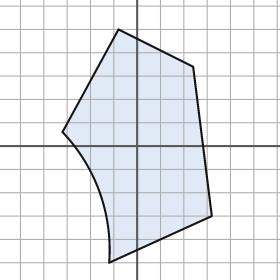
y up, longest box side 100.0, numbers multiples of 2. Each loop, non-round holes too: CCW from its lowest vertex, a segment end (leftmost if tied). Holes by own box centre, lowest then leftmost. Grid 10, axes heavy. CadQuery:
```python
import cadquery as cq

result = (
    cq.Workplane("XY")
    .moveTo(-12.0, -50.0)
    .lineTo(32.0, -30.0)
    .lineTo(24.0, 34.0)
    .lineTo(-8.0, 50.0)
    .lineTo(-32.0, 6.0)
    .threePointArc((-16.0, -20.0), (-12.0, -50.0))
    .close()
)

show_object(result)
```